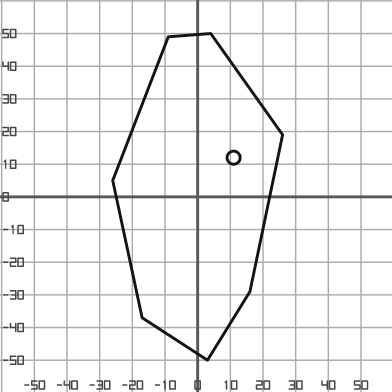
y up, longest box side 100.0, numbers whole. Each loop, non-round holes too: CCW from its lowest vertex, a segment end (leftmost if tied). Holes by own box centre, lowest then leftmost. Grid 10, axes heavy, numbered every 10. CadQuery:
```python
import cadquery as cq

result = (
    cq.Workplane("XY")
    .moveTo(3.0, -50.0)
    .lineTo(16.0, -29.0)
    .lineTo(26.0, 19.0)
    .lineTo(4.0, 50.0)
    .lineTo(-9.0, 49.0)
    .lineTo(-26.0, 5.0)
    .lineTo(-17.0, -37.0)
    .close()
    .moveTo(11.0, 12.0)
    .circle(2.0)
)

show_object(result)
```